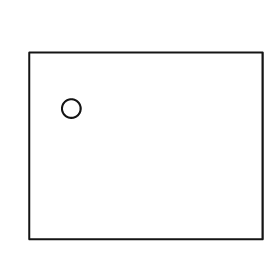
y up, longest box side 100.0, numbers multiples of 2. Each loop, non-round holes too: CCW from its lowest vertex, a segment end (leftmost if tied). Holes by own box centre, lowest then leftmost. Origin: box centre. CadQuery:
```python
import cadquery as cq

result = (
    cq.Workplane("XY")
    .moveTo(-50.0, -40.0)
    .lineTo(50.0, -40.0)
    .lineTo(50.0, 40.0)
    .lineTo(-50.0, 40.0)
    .close()
    .moveTo(-32.0, 16.0)
    .circle(4.0)
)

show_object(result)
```